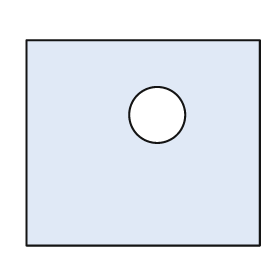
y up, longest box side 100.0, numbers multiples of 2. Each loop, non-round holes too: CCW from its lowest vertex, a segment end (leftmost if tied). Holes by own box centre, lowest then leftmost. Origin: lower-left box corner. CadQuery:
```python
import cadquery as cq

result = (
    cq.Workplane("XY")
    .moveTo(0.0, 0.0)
    .lineTo(100.0, 0.0)
    .lineTo(100.0, 88.0)
    .lineTo(0.0, 88.0)
    .close()
    .moveTo(56.0, 56.0)
    .circle(12.0)
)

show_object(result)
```